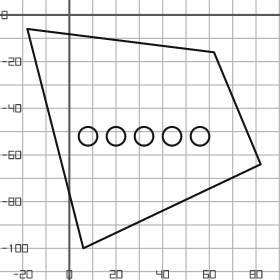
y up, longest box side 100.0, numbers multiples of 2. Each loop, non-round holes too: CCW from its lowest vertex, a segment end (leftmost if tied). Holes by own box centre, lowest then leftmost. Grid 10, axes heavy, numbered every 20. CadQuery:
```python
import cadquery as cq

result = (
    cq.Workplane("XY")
    .moveTo(6.0, -100.0)
    .lineTo(82.0, -64.0)
    .lineTo(62.0, -16.0)
    .lineTo(-18.0, -6.0)
    .close()
    .moveTo(8.0, -52.0)
    .circle(4.0)
    .moveTo(20.0, -52.0)
    .circle(4.0)
    .moveTo(32.0, -52.0)
    .circle(4.0)
    .moveTo(44.0, -52.0)
    .circle(4.0)
    .moveTo(56.0, -52.0)
    .circle(4.0)
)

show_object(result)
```